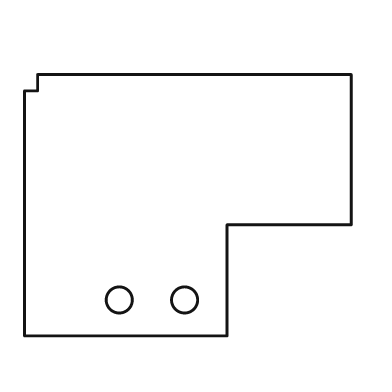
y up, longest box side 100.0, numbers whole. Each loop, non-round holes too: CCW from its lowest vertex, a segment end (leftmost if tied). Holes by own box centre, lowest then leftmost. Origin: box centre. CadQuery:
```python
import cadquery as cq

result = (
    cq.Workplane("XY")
    .moveTo(-50.0, -40.0)
    .lineTo(12.0, -40.0)
    .lineTo(12.0, -6.0)
    .lineTo(50.0, -6.0)
    .lineTo(50.0, 40.0)
    .lineTo(-46.0, 40.0)
    .lineTo(-46.0, 35.0)
    .lineTo(-50.0, 35.0)
    .close()
    .moveTo(-21.0, -29.0)
    .circle(4.0)
    .moveTo(-1.0, -29.0)
    .circle(4.0)
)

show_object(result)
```